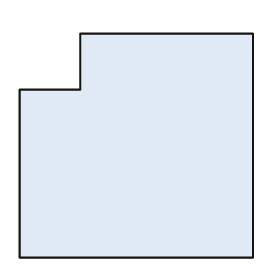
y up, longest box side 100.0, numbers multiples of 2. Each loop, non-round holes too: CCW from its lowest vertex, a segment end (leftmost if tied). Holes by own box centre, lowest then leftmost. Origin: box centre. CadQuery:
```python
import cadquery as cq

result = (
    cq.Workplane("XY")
    .moveTo(-50.0, -48.0)
    .lineTo(50.0, -48.0)
    .lineTo(50.0, 48.0)
    .lineTo(-24.0, 48.0)
    .lineTo(-24.0, 24.0)
    .lineTo(-50.0, 24.0)
    .close()
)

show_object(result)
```